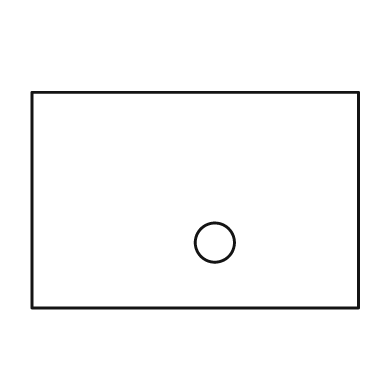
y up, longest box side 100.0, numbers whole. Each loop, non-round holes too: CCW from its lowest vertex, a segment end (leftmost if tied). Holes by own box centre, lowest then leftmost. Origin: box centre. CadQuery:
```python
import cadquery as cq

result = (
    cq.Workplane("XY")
    .moveTo(-50.0, -33.0)
    .lineTo(50.0, -33.0)
    .lineTo(50.0, 33.0)
    .lineTo(-50.0, 33.0)
    .close()
    .moveTo(6.0, -13.0)
    .circle(6.0)
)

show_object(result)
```